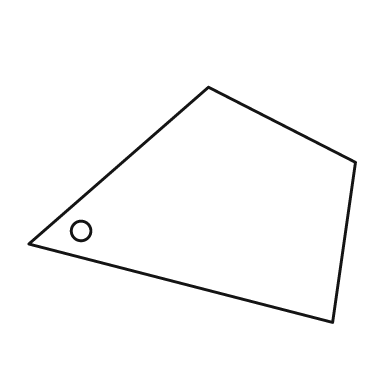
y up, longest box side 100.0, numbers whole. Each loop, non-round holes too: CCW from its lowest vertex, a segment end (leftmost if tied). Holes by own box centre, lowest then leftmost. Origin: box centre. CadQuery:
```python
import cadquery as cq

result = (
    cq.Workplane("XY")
    .moveTo(43.0, -36.0)
    .lineTo(50.0, 13.0)
    .lineTo(5.0, 36.0)
    .lineTo(-50.0, -12.0)
    .close()
    .moveTo(-34.0, -8.0)
    .circle(3.0)
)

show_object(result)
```